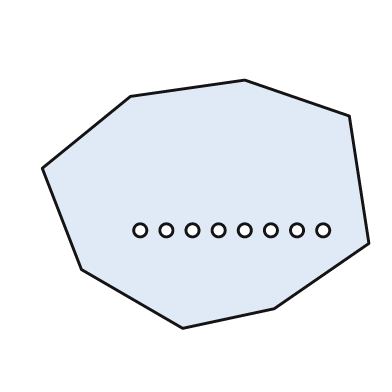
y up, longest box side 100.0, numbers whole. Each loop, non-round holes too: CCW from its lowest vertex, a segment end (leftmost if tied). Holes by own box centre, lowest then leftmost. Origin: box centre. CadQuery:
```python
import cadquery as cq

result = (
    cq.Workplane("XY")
    .moveTo(-7.0, -38.0)
    .lineTo(21.0, -32.0)
    .lineTo(50.0, -12.0)
    .lineTo(44.0, 27.0)
    .lineTo(12.0, 38.0)
    .lineTo(-23.0, 33.0)
    .lineTo(-50.0, 11.0)
    .lineTo(-38.0, -20.0)
    .close()
    .moveTo(-20.0, -8.0)
    .circle(2.0)
    .moveTo(-12.0, -8.0)
    .circle(2.0)
    .moveTo(-4.0, -8.0)
    .circle(2.0)
    .moveTo(4.0, -8.0)
    .circle(2.0)
    .moveTo(12.0, -8.0)
    .circle(2.0)
    .moveTo(20.0, -8.0)
    .circle(2.0)
    .moveTo(28.0, -8.0)
    .circle(2.0)
    .moveTo(36.0, -8.0)
    .circle(2.0)
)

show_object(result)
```